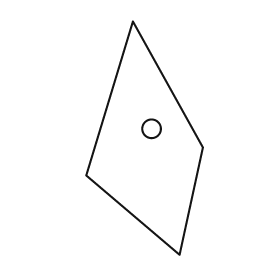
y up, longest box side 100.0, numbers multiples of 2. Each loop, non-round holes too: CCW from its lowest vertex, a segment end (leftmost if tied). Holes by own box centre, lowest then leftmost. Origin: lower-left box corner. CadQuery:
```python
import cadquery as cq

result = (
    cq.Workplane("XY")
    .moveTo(40.0, 0.0)
    .lineTo(50.0, 46.0)
    .lineTo(20.0, 100.0)
    .lineTo(0.0, 34.0)
    .close()
    .moveTo(28.0, 54.0)
    .circle(4.0)
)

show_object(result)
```